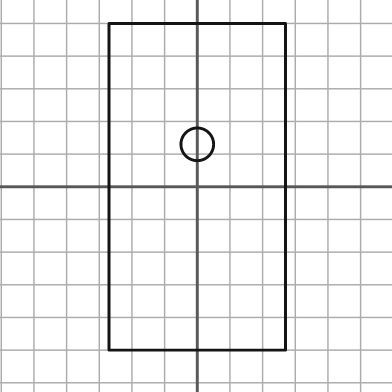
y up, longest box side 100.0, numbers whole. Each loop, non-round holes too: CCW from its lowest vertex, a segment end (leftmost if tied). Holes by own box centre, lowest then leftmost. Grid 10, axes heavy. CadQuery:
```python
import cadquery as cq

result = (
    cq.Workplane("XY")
    .moveTo(-27.0, -50.0)
    .lineTo(27.0, -50.0)
    .lineTo(27.0, 50.0)
    .lineTo(-27.0, 50.0)
    .close()
    .moveTo(0.0, 13.0)
    .circle(5.0)
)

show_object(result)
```